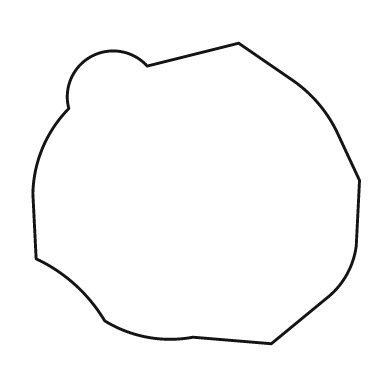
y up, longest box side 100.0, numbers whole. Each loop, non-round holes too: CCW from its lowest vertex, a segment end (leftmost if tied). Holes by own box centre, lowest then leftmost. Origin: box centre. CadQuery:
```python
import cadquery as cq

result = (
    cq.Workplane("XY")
    .moveTo(23.0, -46.0)
    .lineTo(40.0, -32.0)
    .threePointArc((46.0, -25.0), (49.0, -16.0))
    .lineTo(50.0, 4.0)
    .lineTo(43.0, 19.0)
    .threePointArc((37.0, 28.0), (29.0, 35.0))
    .lineTo(13.0, 46.0)
    .lineTo(-15.0, 39.0)
    .threePointArc((-32.0, 42.0), (-39.0, 26.0))
    .threePointArc((-47.0, 14.0), (-50.0, 0.0))
    .lineTo(-49.0, -20.0)
    .threePointArc((-37.0, -28.0), (-28.0, -39.0))
    .threePointArc((-15.0, -44.0), (-1.0, -44.0))
    .close()
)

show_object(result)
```